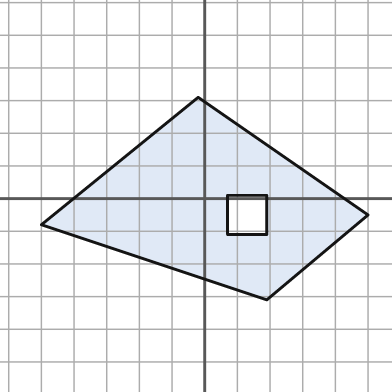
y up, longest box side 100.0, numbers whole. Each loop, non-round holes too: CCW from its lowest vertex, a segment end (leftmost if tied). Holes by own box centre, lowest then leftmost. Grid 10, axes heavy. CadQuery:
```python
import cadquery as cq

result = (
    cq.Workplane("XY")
    .moveTo(19.0, -31.0)
    .lineTo(50.0, -5.0)
    .lineTo(-2.0, 31.0)
    .lineTo(-50.0, -8.0)
    .close()
    .moveTo(7.0, -11.0)
    .lineTo(19.0, -11.0)
    .lineTo(19.0, 1.0)
    .lineTo(7.0, 1.0)
    .close()
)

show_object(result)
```